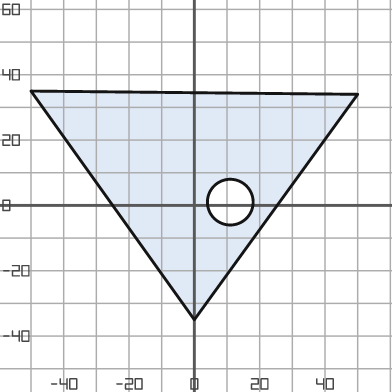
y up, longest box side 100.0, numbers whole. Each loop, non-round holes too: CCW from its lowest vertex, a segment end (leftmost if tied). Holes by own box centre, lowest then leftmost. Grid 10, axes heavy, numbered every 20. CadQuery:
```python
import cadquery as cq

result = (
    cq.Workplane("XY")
    .moveTo(0.0, -35.0)
    .lineTo(50.0, 34.0)
    .lineTo(-50.0, 35.0)
    .close()
    .moveTo(11.0, 1.0)
    .circle(7.0)
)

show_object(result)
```